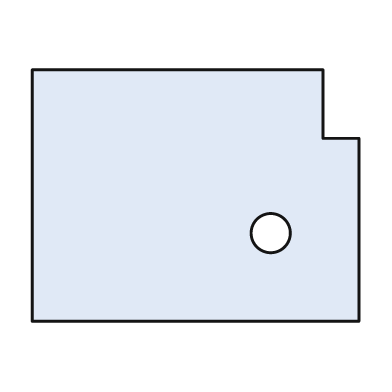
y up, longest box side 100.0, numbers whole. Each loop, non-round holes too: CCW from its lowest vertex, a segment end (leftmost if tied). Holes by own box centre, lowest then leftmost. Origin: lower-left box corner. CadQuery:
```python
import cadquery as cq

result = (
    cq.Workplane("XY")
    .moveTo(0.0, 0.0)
    .lineTo(100.0, 0.0)
    .lineTo(100.0, 56.0)
    .lineTo(89.0, 56.0)
    .lineTo(89.0, 77.0)
    .lineTo(0.0, 77.0)
    .close()
    .moveTo(73.0, 27.0)
    .circle(6.0)
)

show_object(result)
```